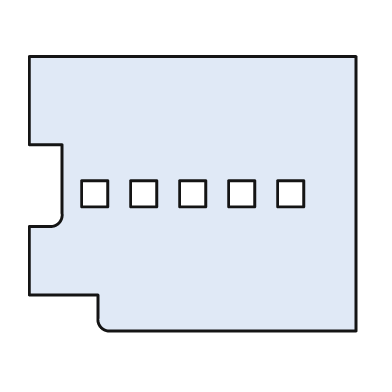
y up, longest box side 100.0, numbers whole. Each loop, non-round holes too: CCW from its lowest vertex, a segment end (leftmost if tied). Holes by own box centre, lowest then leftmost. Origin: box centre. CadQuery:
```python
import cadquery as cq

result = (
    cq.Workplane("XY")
    .moveTo(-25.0, -42.0)
    .lineTo(50.0, -42.0)
    .lineTo(50.0, 42.0)
    .lineTo(-50.0, 42.0)
    .lineTo(-50.0, 15.0)
    .lineTo(-40.0, 15.0)
    .lineTo(-40.0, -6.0)
    .threePointArc((-41.0, -9.0), (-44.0, -10.0))
    .lineTo(-50.0, -10.0)
    .lineTo(-50.0, -31.0)
    .lineTo(-29.0, -31.0)
    .lineTo(-29.0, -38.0)
    .threePointArc((-28.0, -41.0), (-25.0, -42.0))
    .close()
    .moveTo(-34.0, -4.0)
    .lineTo(-26.0, -4.0)
    .lineTo(-26.0, 4.0)
    .lineTo(-34.0, 4.0)
    .close()
    .moveTo(-19.0, -4.0)
    .lineTo(-11.0, -4.0)
    .lineTo(-11.0, 4.0)
    .lineTo(-19.0, 4.0)
    .close()
    .moveTo(-4.0, -4.0)
    .lineTo(4.0, -4.0)
    .lineTo(4.0, 4.0)
    .lineTo(-4.0, 4.0)
    .close()
    .moveTo(11.0, -4.0)
    .lineTo(19.0, -4.0)
    .lineTo(19.0, 4.0)
    .lineTo(11.0, 4.0)
    .close()
    .moveTo(26.0, -4.0)
    .lineTo(34.0, -4.0)
    .lineTo(34.0, 4.0)
    .lineTo(26.0, 4.0)
    .close()
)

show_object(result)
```